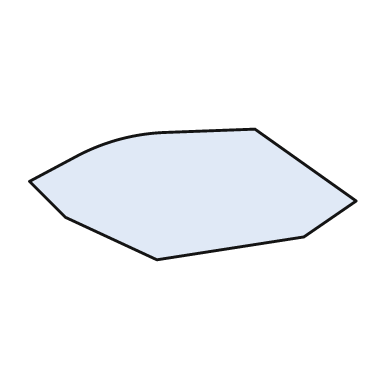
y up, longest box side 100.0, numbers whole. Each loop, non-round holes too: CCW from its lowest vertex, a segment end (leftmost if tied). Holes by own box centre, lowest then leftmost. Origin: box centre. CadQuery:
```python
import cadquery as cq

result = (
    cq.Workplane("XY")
    .moveTo(-11.0, -20.0)
    .lineTo(34.0, -13.0)
    .lineTo(50.0, -2.0)
    .lineTo(19.0, 20.0)
    .lineTo(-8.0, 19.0)
    .threePointArc((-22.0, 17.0), (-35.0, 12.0))
    .lineTo(-50.0, 4.0)
    .lineTo(-39.0, -7.0)
    .close()
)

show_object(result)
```